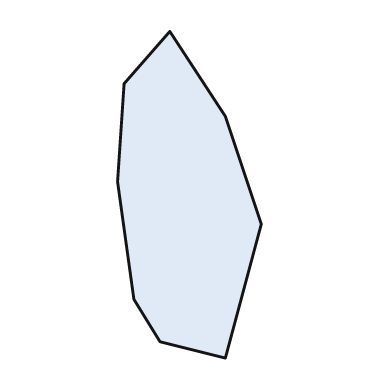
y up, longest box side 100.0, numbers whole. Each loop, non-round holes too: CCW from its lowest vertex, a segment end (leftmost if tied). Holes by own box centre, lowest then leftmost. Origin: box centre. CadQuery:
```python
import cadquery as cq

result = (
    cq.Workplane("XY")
    .moveTo(11.0, -50.0)
    .lineTo(22.0, -9.0)
    .lineTo(11.0, 24.0)
    .lineTo(-6.0, 50.0)
    .lineTo(-20.0, 34.0)
    .lineTo(-22.0, 4.0)
    .lineTo(-17.0, -32.0)
    .lineTo(-9.0, -45.0)
    .close()
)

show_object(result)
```